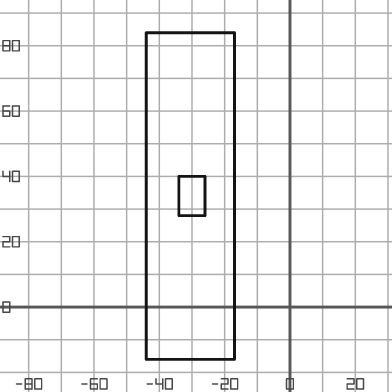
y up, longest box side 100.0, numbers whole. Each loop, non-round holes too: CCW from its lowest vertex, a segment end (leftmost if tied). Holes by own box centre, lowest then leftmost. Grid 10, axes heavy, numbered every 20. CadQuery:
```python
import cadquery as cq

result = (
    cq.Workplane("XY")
    .moveTo(-44.0, -16.0)
    .lineTo(-17.0, -16.0)
    .lineTo(-17.0, 84.0)
    .lineTo(-44.0, 84.0)
    .close()
    .moveTo(-34.0, 28.0)
    .lineTo(-26.0, 28.0)
    .lineTo(-26.0, 40.0)
    .lineTo(-34.0, 40.0)
    .close()
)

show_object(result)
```